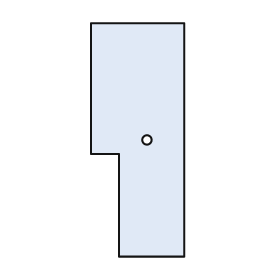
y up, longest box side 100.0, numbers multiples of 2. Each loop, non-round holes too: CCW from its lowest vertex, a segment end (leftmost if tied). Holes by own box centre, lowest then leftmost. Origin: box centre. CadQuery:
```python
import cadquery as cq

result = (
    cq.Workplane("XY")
    .moveTo(-8.0, -50.0)
    .lineTo(20.0, -50.0)
    .lineTo(20.0, 50.0)
    .lineTo(-20.0, 50.0)
    .lineTo(-20.0, -6.0)
    .lineTo(-8.0, -6.0)
    .close()
    .moveTo(4.0, 0.0)
    .circle(2.0)
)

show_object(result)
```